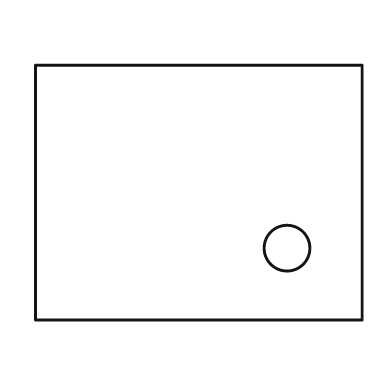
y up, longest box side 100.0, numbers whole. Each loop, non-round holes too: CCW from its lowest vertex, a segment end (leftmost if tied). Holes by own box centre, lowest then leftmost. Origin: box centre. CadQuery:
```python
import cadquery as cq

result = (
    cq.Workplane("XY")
    .moveTo(-50.0, -39.0)
    .lineTo(50.0, -39.0)
    .lineTo(50.0, 39.0)
    .lineTo(-50.0, 39.0)
    .close()
    .moveTo(27.0, -17.0)
    .circle(7.0)
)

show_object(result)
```